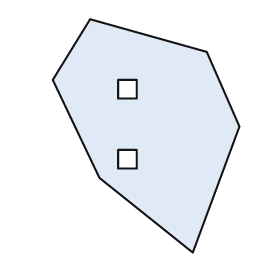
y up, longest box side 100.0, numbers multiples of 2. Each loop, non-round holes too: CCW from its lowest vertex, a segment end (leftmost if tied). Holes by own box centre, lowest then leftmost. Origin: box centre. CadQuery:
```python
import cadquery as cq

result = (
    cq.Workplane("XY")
    .moveTo(20.0, -50.0)
    .lineTo(40.0, 4.0)
    .lineTo(26.0, 36.0)
    .lineTo(-24.0, 50.0)
    .lineTo(-40.0, 24.0)
    .lineTo(-20.0, -18.0)
    .close()
    .moveTo(-12.0, -14.0)
    .lineTo(-4.0, -14.0)
    .lineTo(-4.0, -6.0)
    .lineTo(-12.0, -6.0)
    .close()
    .moveTo(-12.0, 16.0)
    .lineTo(-4.0, 16.0)
    .lineTo(-4.0, 24.0)
    .lineTo(-12.0, 24.0)
    .close()
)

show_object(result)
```